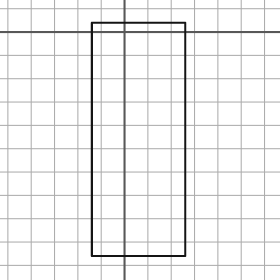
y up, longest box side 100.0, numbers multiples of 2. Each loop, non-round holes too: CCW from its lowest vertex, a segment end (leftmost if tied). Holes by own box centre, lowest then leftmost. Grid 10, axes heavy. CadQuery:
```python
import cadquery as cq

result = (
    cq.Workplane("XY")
    .moveTo(-14.0, -96.0)
    .lineTo(26.0, -96.0)
    .lineTo(26.0, 4.0)
    .lineTo(-14.0, 4.0)
    .close()
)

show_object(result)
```